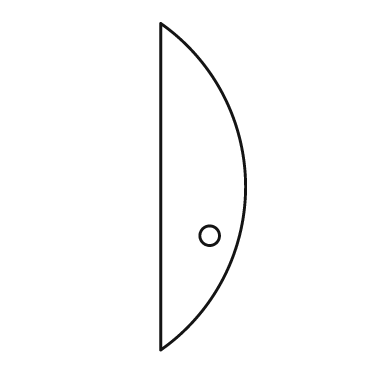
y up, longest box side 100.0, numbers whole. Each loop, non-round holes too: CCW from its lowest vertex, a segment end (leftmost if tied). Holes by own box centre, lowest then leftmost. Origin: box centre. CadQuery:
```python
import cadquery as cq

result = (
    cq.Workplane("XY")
    .moveTo(-13.0, -50.0)
    .threePointArc((13.0, 0.0), (-13.0, 50.0))
    .close()
    .moveTo(2.0, -15.0)
    .circle(3.0)
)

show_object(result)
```